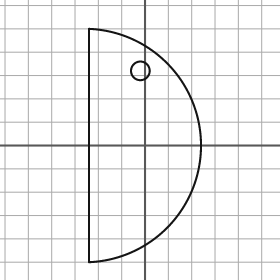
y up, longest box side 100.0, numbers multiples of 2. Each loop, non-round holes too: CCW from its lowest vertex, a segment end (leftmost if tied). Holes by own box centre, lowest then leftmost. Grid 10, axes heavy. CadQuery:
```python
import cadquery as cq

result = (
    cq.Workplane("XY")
    .moveTo(-24.0, -50.0)
    .threePointArc((24.0, 0.0), (-24.0, 50.0))
    .close()
    .moveTo(-2.0, 32.0)
    .circle(4.0)
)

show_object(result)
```